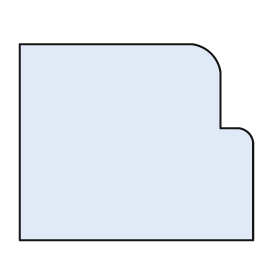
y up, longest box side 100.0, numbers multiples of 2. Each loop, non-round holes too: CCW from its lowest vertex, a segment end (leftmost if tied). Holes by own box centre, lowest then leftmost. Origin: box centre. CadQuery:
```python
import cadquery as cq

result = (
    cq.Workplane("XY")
    .moveTo(-50.0, -42.0)
    .lineTo(50.0, -42.0)
    .lineTo(50.0, 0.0)
    .threePointArc((48.0, 4.0), (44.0, 6.0))
    .lineTo(36.0, 6.0)
    .lineTo(36.0, 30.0)
    .threePointArc((32.0, 38.0), (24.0, 42.0))
    .lineTo(-50.0, 42.0)
    .close()
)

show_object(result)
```